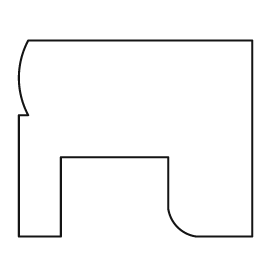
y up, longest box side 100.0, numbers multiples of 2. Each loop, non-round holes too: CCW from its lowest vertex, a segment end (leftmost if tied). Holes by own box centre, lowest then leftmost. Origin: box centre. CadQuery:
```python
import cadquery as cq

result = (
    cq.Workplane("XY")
    .moveTo(-50.0, -42.0)
    .lineTo(-32.0, -42.0)
    .lineTo(-32.0, -8.0)
    .lineTo(14.0, -8.0)
    .lineTo(14.0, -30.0)
    .threePointArc((18.0, -38.0), (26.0, -42.0))
    .lineTo(50.0, -42.0)
    .lineTo(50.0, 42.0)
    .lineTo(-46.0, 42.0)
    .threePointArc((-50.0, 26.0), (-46.0, 10.0))
    .lineTo(-50.0, 10.0)
    .close()
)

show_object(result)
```